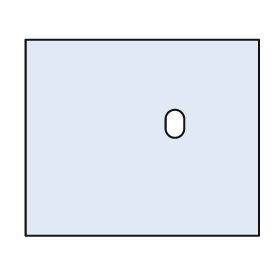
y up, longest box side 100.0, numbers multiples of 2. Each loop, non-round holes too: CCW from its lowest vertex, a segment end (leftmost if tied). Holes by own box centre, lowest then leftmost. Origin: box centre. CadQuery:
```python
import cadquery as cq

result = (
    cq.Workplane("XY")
    .moveTo(-50.0, -42.0)
    .lineTo(50.0, -42.0)
    .lineTo(50.0, 42.0)
    .lineTo(-50.0, 42.0)
    .close()
    .moveTo(10.0, 4.0)
    .threePointArc((14.0, 0.0), (18.0, 4.0))
    .lineTo(18.0, 8.0)
    .threePointArc((14.0, 12.0), (10.0, 8.0))
    .close()
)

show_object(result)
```